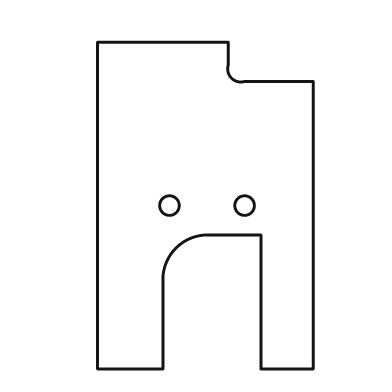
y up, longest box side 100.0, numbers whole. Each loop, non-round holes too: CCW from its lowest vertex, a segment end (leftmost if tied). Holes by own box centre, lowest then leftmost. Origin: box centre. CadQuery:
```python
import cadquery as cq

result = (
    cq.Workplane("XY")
    .moveTo(-33.0, -50.0)
    .lineTo(-13.0, -50.0)
    .lineTo(-13.0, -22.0)
    .threePointArc((-9.0, -13.0), (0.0, -9.0))
    .lineTo(17.0, -9.0)
    .lineTo(17.0, -50.0)
    .lineTo(33.0, -50.0)
    .lineTo(33.0, 38.0)
    .lineTo(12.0, 38.0)
    .threePointArc((8.0, 39.0), (7.0, 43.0))
    .lineTo(7.0, 50.0)
    .lineTo(-33.0, 50.0)
    .close()
    .moveTo(-11.0, 0.0)
    .circle(3.0)
    .moveTo(12.0, 0.0)
    .circle(3.0)
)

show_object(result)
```